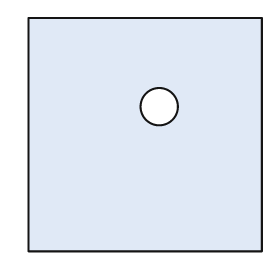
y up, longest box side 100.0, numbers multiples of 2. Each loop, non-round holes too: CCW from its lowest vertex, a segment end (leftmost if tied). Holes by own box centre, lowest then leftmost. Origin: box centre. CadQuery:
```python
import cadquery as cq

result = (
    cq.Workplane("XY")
    .moveTo(-50.0, -50.0)
    .lineTo(50.0, -50.0)
    .lineTo(50.0, 50.0)
    .lineTo(-50.0, 50.0)
    .close()
    .moveTo(6.0, 12.0)
    .circle(8.0)
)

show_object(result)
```